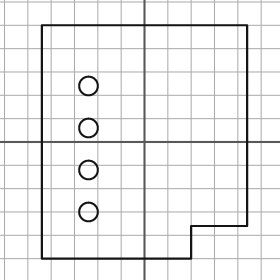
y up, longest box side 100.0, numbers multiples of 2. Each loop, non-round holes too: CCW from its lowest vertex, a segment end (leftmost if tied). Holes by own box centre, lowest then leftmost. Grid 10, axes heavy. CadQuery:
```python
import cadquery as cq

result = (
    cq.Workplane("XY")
    .moveTo(-44.0, -50.0)
    .lineTo(20.0, -50.0)
    .lineTo(20.0, -36.0)
    .lineTo(44.0, -36.0)
    .lineTo(44.0, 50.0)
    .lineTo(-44.0, 50.0)
    .close()
    .moveTo(-24.0, -30.0)
    .circle(4.0)
    .moveTo(-24.0, -12.0)
    .circle(4.0)
    .moveTo(-24.0, 6.0)
    .circle(4.0)
    .moveTo(-24.0, 24.0)
    .circle(4.0)
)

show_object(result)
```